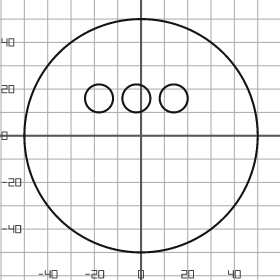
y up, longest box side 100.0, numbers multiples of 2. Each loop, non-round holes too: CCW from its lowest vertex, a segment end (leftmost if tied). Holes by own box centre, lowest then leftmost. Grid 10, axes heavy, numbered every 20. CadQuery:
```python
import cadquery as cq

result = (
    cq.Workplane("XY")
    .moveTo(0.0, 0.0)
    .circle(50.0)
    .moveTo(-18.0, 16.0)
    .circle(6.0)
    .moveTo(-2.0, 16.0)
    .circle(6.0)
    .moveTo(14.0, 16.0)
    .circle(6.0)
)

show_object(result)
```